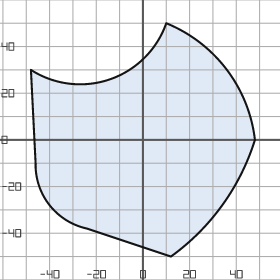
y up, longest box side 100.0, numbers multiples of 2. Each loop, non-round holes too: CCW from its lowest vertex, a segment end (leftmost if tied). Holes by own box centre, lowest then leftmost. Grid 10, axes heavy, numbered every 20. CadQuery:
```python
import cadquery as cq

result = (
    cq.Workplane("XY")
    .moveTo(12.0, -50.0)
    .threePointArc((34.0, -28.0), (48.0, 0.0))
    .threePointArc((36.0, 30.0), (10.0, 50.0))
    .threePointArc((-14.0, 26.0), (-48.0, 30.0))
    .lineTo(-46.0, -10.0)
    .threePointArc((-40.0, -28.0), (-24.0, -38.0))
    .close()
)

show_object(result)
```